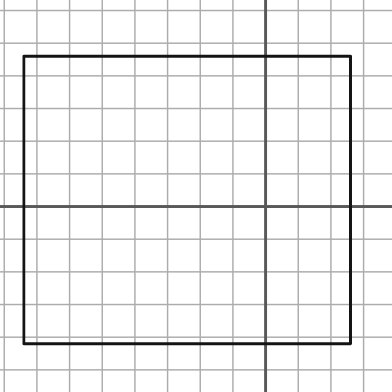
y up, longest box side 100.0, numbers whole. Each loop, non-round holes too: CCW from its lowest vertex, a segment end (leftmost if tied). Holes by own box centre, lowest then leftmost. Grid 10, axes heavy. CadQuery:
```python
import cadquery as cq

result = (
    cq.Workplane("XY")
    .moveTo(-74.0, -42.0)
    .lineTo(26.0, -42.0)
    .lineTo(26.0, 46.0)
    .lineTo(-74.0, 46.0)
    .close()
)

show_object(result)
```